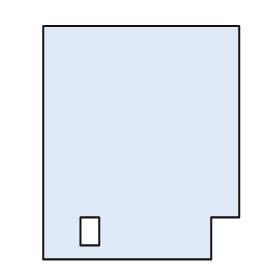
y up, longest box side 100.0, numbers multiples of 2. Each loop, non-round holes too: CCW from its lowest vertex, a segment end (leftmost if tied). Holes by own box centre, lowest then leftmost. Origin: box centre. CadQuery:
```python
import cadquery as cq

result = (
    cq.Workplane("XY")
    .moveTo(-42.0, -50.0)
    .lineTo(30.0, -50.0)
    .lineTo(30.0, -32.0)
    .lineTo(42.0, -32.0)
    .lineTo(42.0, 50.0)
    .lineTo(-42.0, 50.0)
    .close()
    .moveTo(-26.0, -44.0)
    .lineTo(-18.0, -44.0)
    .lineTo(-18.0, -32.0)
    .lineTo(-26.0, -32.0)
    .close()
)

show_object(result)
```